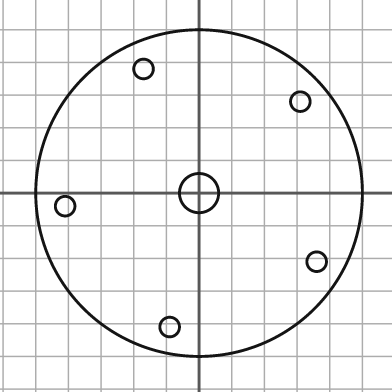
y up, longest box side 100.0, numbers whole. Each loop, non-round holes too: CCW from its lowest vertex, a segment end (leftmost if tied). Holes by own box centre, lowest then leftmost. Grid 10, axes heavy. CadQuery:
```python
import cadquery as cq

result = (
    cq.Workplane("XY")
    .moveTo(0.0, 0.0)
    .circle(50.0)
    .moveTo(-9.0, -41.0)
    .circle(3.0)
    .moveTo(36.0, -21.0)
    .circle(3.0)
    .moveTo(-41.0, -4.0)
    .circle(3.0)
    .moveTo(0.0, 0.0)
    .circle(6.0)
    .moveTo(31.0, 28.0)
    .circle(3.0)
    .moveTo(-17.0, 38.0)
    .circle(3.0)
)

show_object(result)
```